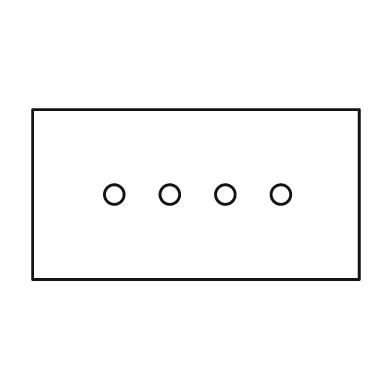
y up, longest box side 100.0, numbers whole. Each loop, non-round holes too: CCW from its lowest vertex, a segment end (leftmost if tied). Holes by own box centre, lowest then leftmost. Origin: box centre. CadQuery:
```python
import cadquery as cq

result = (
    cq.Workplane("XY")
    .moveTo(-50.0, -26.0)
    .lineTo(50.0, -26.0)
    .lineTo(50.0, 26.0)
    .lineTo(-50.0, 26.0)
    .close()
    .moveTo(-25.0, 0.0)
    .circle(3.0)
    .moveTo(-8.0, 0.0)
    .circle(3.0)
    .moveTo(9.0, 0.0)
    .circle(3.0)
    .moveTo(26.0, 0.0)
    .circle(3.0)
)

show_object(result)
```